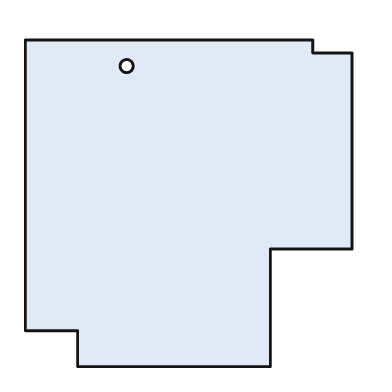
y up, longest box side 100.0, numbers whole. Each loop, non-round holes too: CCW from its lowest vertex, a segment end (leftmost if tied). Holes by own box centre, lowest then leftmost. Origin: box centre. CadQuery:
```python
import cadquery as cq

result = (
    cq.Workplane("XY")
    .moveTo(-34.0, -50.0)
    .lineTo(25.0, -50.0)
    .lineTo(25.0, -14.0)
    .lineTo(50.0, -14.0)
    .lineTo(50.0, 46.0)
    .lineTo(38.0, 46.0)
    .lineTo(38.0, 50.0)
    .lineTo(-50.0, 50.0)
    .lineTo(-50.0, -39.0)
    .lineTo(-34.0, -39.0)
    .close()
    .moveTo(-19.0, 42.0)
    .circle(2.0)
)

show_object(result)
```